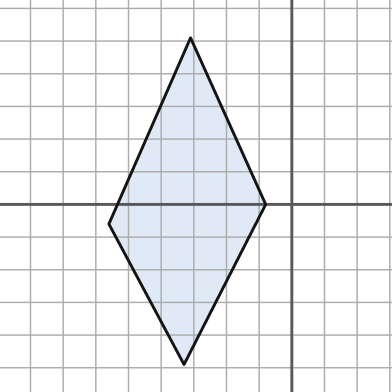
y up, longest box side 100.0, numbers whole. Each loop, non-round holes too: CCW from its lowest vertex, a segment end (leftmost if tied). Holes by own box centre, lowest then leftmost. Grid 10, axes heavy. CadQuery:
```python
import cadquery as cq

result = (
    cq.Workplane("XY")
    .moveTo(-33.0, -49.0)
    .lineTo(-8.0, 0.0)
    .lineTo(-31.0, 51.0)
    .lineTo(-56.0, -6.0)
    .close()
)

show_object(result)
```